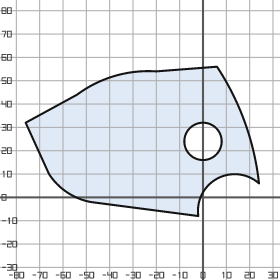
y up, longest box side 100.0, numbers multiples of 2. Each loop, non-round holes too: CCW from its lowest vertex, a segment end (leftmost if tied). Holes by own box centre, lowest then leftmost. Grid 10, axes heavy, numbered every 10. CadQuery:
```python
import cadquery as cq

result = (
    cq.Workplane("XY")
    .moveTo(-2.0, -8.0)
    .threePointArc((6.0, 8.0), (24.0, 6.0))
    .threePointArc((18.0, 32.0), (6.0, 56.0))
    .lineTo(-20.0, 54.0)
    .threePointArc((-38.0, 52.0), (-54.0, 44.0))
    .lineTo(-76.0, 32.0)
    .lineTo(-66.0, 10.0)
    .threePointArc((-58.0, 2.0), (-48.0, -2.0))
    .close()
    .moveTo(0.0, 24.0)
    .circle(8.0)
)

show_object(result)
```